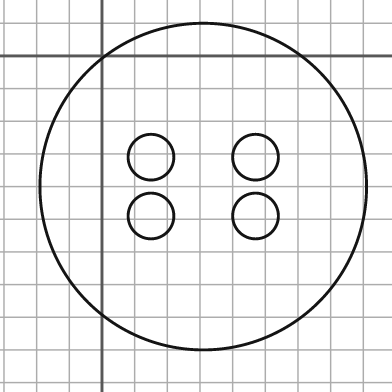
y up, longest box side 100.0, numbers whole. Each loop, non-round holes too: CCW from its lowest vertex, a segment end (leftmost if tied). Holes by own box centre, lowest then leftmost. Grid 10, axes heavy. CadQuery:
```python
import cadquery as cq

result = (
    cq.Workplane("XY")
    .moveTo(31.0, -40.0)
    .circle(50.0)
    .moveTo(15.0, -49.0)
    .circle(7.0)
    .moveTo(47.0, -49.0)
    .circle(7.0)
    .moveTo(15.0, -31.0)
    .circle(7.0)
    .moveTo(47.0, -31.0)
    .circle(7.0)
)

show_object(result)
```